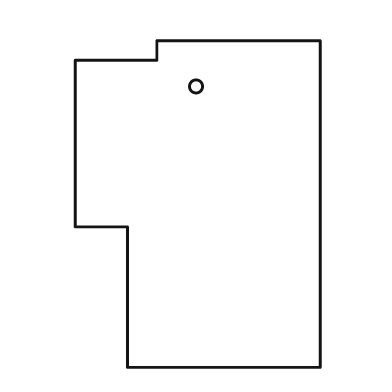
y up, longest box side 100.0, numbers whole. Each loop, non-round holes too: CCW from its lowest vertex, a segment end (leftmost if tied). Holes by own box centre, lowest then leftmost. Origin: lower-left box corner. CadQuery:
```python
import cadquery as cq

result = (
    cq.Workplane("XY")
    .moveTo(16.0, 0.0)
    .lineTo(75.0, 0.0)
    .lineTo(75.0, 100.0)
    .lineTo(25.0, 100.0)
    .lineTo(25.0, 94.0)
    .lineTo(0.0, 94.0)
    .lineTo(0.0, 43.0)
    .lineTo(16.0, 43.0)
    .close()
    .moveTo(37.0, 86.0)
    .circle(2.0)
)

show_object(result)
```